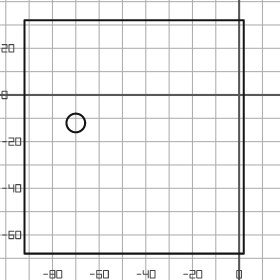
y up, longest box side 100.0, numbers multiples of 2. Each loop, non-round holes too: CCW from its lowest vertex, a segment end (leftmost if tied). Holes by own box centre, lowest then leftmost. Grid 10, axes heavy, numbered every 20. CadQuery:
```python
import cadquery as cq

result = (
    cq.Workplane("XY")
    .moveTo(-92.0, -68.0)
    .lineTo(2.0, -68.0)
    .lineTo(2.0, 32.0)
    .lineTo(-92.0, 32.0)
    .close()
    .moveTo(-70.0, -12.0)
    .circle(4.0)
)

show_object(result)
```